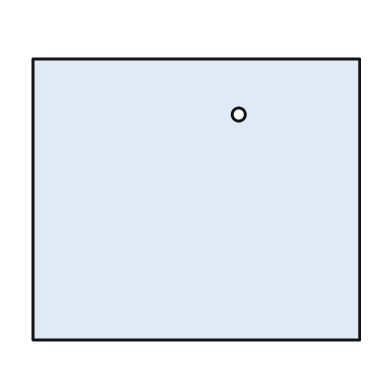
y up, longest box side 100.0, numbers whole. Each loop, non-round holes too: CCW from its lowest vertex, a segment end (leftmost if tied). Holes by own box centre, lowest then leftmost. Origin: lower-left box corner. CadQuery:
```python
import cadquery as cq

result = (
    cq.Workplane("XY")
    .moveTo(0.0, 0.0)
    .lineTo(100.0, 0.0)
    .lineTo(100.0, 86.0)
    .lineTo(0.0, 86.0)
    .close()
    .moveTo(63.0, 69.0)
    .circle(2.0)
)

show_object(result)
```